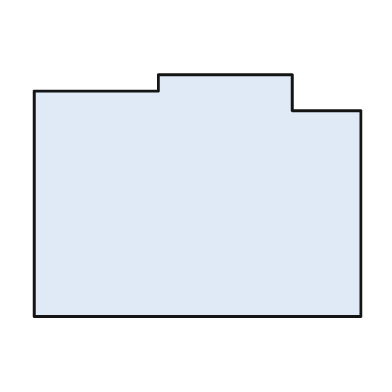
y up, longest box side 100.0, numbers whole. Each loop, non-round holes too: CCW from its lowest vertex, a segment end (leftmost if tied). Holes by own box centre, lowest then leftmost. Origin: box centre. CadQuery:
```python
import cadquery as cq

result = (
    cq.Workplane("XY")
    .moveTo(-50.0, -37.0)
    .lineTo(50.0, -37.0)
    .lineTo(50.0, 26.0)
    .lineTo(29.0, 26.0)
    .lineTo(29.0, 37.0)
    .lineTo(-12.0, 37.0)
    .lineTo(-12.0, 32.0)
    .lineTo(-50.0, 32.0)
    .close()
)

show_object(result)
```